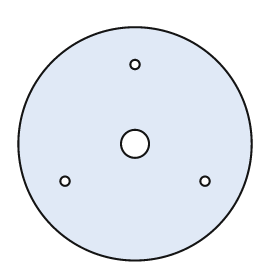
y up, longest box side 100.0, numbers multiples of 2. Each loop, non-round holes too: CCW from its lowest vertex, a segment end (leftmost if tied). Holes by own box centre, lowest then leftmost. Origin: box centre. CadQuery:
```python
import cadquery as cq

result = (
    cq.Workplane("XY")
    .moveTo(0.0, 0.0)
    .circle(50.0)
    .moveTo(-30.0, -16.0)
    .circle(2.0)
    .moveTo(30.0, -16.0)
    .circle(2.0)
    .moveTo(0.0, 0.0)
    .circle(6.0)
    .moveTo(0.0, 34.0)
    .circle(2.0)
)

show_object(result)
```